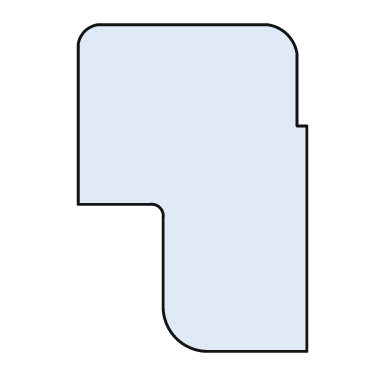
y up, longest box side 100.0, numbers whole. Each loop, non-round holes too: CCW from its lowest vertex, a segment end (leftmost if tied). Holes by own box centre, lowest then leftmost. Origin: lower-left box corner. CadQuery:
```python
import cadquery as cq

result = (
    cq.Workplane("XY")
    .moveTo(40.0, 0.0)
    .lineTo(70.0, 0.0)
    .lineTo(70.0, 69.0)
    .lineTo(67.0, 69.0)
    .lineTo(67.0, 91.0)
    .threePointArc((64.0, 97.0), (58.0, 100.0))
    .lineTo(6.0, 100.0)
    .threePointArc((2.0, 98.0), (0.0, 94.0))
    .lineTo(0.0, 45.0)
    .lineTo(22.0, 45.0)
    .threePointArc((25.0, 44.0), (26.0, 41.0))
    .lineTo(26.0, 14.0)
    .threePointArc((30.0, 4.0), (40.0, 0.0))
    .close()
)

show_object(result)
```